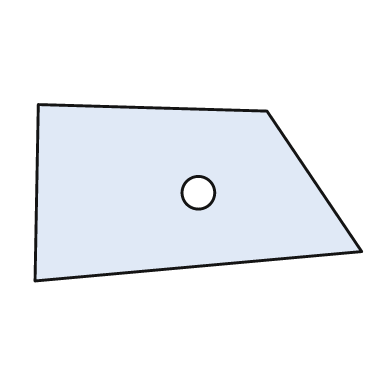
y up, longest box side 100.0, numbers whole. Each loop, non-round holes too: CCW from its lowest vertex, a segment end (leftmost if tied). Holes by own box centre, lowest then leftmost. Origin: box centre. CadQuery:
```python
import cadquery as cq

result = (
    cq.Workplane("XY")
    .moveTo(-50.0, -27.0)
    .lineTo(50.0, -18.0)
    .lineTo(21.0, 25.0)
    .lineTo(-49.0, 27.0)
    .close()
    .moveTo(0.0, 0.0)
    .circle(5.0)
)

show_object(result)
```